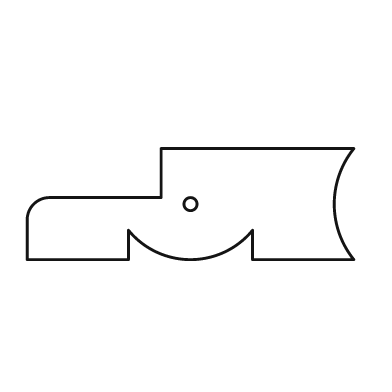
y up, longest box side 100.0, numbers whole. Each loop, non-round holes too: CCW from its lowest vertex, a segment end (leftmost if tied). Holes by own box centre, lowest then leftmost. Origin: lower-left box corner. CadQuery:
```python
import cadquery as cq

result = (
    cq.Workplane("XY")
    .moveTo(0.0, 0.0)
    .lineTo(31.0, 0.0)
    .lineTo(31.0, 9.0)
    .threePointArc((50.0, 0.0), (69.0, 9.0))
    .lineTo(69.0, 0.0)
    .lineTo(100.0, 0.0)
    .threePointArc((94.0, 17.0), (100.0, 34.0))
    .lineTo(41.0, 34.0)
    .lineTo(41.0, 19.0)
    .lineTo(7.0, 19.0)
    .threePointArc((2.0, 17.0), (0.0, 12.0))
    .close()
    .moveTo(50.0, 17.0)
    .circle(2.0)
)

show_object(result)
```